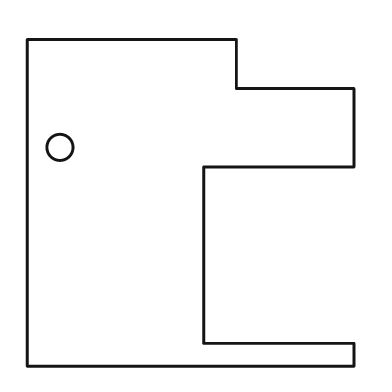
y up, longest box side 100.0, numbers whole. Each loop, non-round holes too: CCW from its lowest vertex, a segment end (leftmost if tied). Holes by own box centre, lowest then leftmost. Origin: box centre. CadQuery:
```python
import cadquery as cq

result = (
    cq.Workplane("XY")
    .moveTo(-50.0, -50.0)
    .lineTo(50.0, -50.0)
    .lineTo(50.0, -43.0)
    .lineTo(4.0, -43.0)
    .lineTo(4.0, 11.0)
    .lineTo(50.0, 11.0)
    .lineTo(50.0, 35.0)
    .lineTo(14.0, 35.0)
    .lineTo(14.0, 50.0)
    .lineTo(-50.0, 50.0)
    .close()
    .moveTo(-40.0, 17.0)
    .circle(4.0)
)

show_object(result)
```